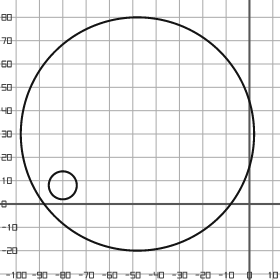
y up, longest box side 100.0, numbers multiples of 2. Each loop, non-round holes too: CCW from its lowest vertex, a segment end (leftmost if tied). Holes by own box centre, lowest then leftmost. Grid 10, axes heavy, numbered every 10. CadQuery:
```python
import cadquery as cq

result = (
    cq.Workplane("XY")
    .moveTo(-48.0, 30.0)
    .circle(50.0)
    .moveTo(-80.0, 8.0)
    .circle(6.0)
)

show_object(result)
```